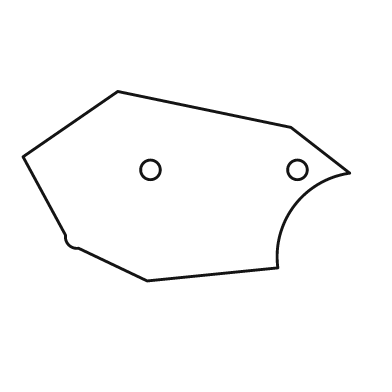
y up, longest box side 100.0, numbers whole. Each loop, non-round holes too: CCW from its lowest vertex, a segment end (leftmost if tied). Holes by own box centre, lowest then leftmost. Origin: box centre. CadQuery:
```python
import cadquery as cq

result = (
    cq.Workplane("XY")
    .moveTo(-12.0, -29.0)
    .lineTo(28.0, -25.0)
    .threePointArc((33.0, -6.0), (50.0, 4.0))
    .lineTo(32.0, 18.0)
    .lineTo(-21.0, 29.0)
    .lineTo(-50.0, 9.0)
    .lineTo(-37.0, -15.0)
    .threePointArc((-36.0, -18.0), (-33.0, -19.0))
    .close()
    .moveTo(-11.0, 5.0)
    .circle(3.0)
    .moveTo(34.0, 5.0)
    .circle(3.0)
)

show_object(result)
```